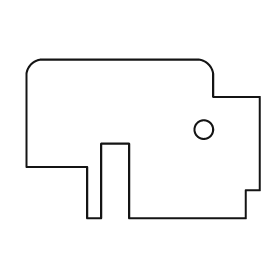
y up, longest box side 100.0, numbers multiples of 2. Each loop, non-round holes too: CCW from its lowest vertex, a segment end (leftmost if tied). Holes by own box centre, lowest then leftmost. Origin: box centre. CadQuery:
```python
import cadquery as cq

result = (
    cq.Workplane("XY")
    .moveTo(-24.0, -34.0)
    .lineTo(-18.0, -34.0)
    .lineTo(-18.0, -2.0)
    .lineTo(-6.0, -2.0)
    .lineTo(-6.0, -34.0)
    .lineTo(44.0, -34.0)
    .lineTo(44.0, -22.0)
    .lineTo(50.0, -22.0)
    .lineTo(50.0, 18.0)
    .lineTo(30.0, 18.0)
    .lineTo(30.0, 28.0)
    .threePointArc((28.0, 32.0), (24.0, 34.0))
    .lineTo(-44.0, 34.0)
    .threePointArc((-48.0, 32.0), (-50.0, 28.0))
    .lineTo(-50.0, -12.0)
    .lineTo(-24.0, -12.0)
    .close()
    .moveTo(26.0, 4.0)
    .circle(4.0)
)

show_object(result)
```